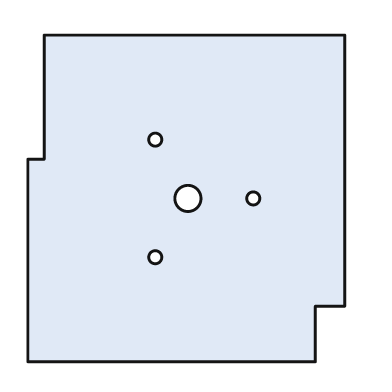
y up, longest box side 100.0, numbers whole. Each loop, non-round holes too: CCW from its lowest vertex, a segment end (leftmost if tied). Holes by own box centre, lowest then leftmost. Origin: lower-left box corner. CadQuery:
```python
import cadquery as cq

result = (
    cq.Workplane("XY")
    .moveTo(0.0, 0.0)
    .lineTo(88.0, 0.0)
    .lineTo(88.0, 17.0)
    .lineTo(97.0, 17.0)
    .lineTo(97.0, 100.0)
    .lineTo(5.0, 100.0)
    .lineTo(5.0, 62.0)
    .lineTo(0.0, 62.0)
    .close()
    .moveTo(39.0, 32.0)
    .circle(2.0)
    .moveTo(49.0, 50.0)
    .circle(4.0)
    .moveTo(69.0, 50.0)
    .circle(2.0)
    .moveTo(39.0, 68.0)
    .circle(2.0)
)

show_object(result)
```